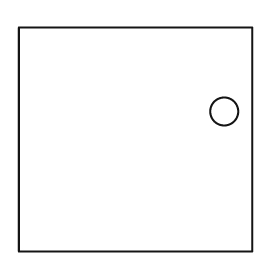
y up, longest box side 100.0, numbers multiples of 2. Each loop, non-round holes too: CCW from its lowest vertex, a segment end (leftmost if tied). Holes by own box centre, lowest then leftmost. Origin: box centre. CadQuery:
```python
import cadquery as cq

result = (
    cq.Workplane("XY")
    .moveTo(-50.0, -48.0)
    .lineTo(50.0, -48.0)
    .lineTo(50.0, 48.0)
    .lineTo(-50.0, 48.0)
    .close()
    .moveTo(38.0, 12.0)
    .circle(6.0)
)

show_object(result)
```